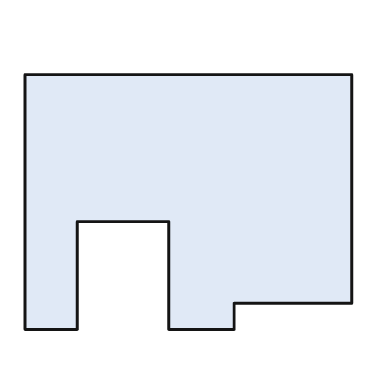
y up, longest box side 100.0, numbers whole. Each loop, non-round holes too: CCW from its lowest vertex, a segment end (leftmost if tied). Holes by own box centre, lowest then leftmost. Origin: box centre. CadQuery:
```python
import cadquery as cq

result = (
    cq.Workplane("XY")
    .moveTo(-50.0, -39.0)
    .lineTo(-34.0, -39.0)
    .lineTo(-34.0, -6.0)
    .lineTo(-6.0, -6.0)
    .lineTo(-6.0, -39.0)
    .lineTo(14.0, -39.0)
    .lineTo(14.0, -31.0)
    .lineTo(50.0, -31.0)
    .lineTo(50.0, 39.0)
    .lineTo(-50.0, 39.0)
    .close()
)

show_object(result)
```